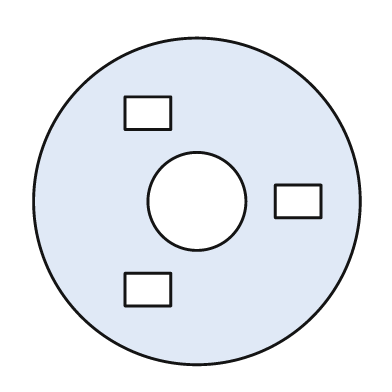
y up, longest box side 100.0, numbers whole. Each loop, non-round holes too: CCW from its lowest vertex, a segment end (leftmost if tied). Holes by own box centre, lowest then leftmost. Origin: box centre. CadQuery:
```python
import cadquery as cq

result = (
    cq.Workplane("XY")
    .moveTo(0.0, 0.0)
    .circle(50.0)
    .moveTo(-22.0, -32.0)
    .lineTo(-8.0, -32.0)
    .lineTo(-8.0, -22.0)
    .lineTo(-22.0, -22.0)
    .close()
    .moveTo(0.0, 0.0)
    .circle(15.0)
    .moveTo(24.0, -5.0)
    .lineTo(38.0, -5.0)
    .lineTo(38.0, 5.0)
    .lineTo(24.0, 5.0)
    .close()
    .moveTo(-22.0, 22.0)
    .lineTo(-8.0, 22.0)
    .lineTo(-8.0, 32.0)
    .lineTo(-22.0, 32.0)
    .close()
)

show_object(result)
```